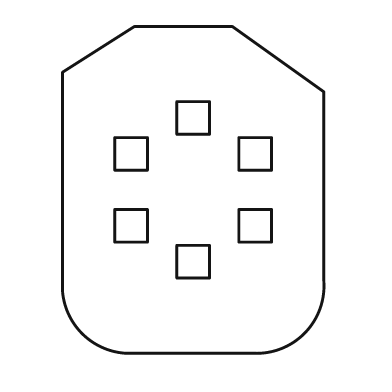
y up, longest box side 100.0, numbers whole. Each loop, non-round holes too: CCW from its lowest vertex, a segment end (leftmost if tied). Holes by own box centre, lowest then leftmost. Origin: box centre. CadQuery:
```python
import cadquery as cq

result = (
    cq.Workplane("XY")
    .moveTo(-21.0, -50.0)
    .lineTo(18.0, -50.0)
    .threePointArc((34.0, -44.0), (40.0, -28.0))
    .lineTo(40.0, 30.0)
    .lineTo(12.0, 50.0)
    .lineTo(-18.0, 50.0)
    .lineTo(-40.0, 36.0)
    .lineTo(-40.0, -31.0)
    .threePointArc((-34.0, -44.0), (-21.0, -50.0))
    .close()
    .moveTo(-5.0, -27.0)
    .lineTo(5.0, -27.0)
    .lineTo(5.0, -17.0)
    .lineTo(-5.0, -17.0)
    .close()
    .moveTo(-24.0, -16.0)
    .lineTo(-14.0, -16.0)
    .lineTo(-14.0, -6.0)
    .lineTo(-24.0, -6.0)
    .close()
    .moveTo(14.0, -16.0)
    .lineTo(24.0, -16.0)
    .lineTo(24.0, -6.0)
    .lineTo(14.0, -6.0)
    .close()
    .moveTo(-24.0, 6.0)
    .lineTo(-14.0, 6.0)
    .lineTo(-14.0, 16.0)
    .lineTo(-24.0, 16.0)
    .close()
    .moveTo(14.0, 6.0)
    .lineTo(24.0, 6.0)
    .lineTo(24.0, 16.0)
    .lineTo(14.0, 16.0)
    .close()
    .moveTo(-5.0, 17.0)
    .lineTo(5.0, 17.0)
    .lineTo(5.0, 27.0)
    .lineTo(-5.0, 27.0)
    .close()
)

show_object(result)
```